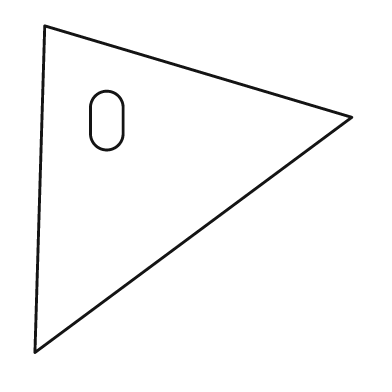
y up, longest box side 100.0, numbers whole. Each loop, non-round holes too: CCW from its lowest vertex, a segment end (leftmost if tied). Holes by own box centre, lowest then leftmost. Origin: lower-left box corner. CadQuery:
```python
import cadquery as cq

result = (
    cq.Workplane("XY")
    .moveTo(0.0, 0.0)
    .lineTo(97.0, 72.0)
    .lineTo(3.0, 100.0)
    .close()
    .moveTo(17.0, 67.0)
    .threePointArc((22.0, 62.0), (27.0, 67.0))
    .lineTo(27.0, 75.0)
    .threePointArc((22.0, 80.0), (17.0, 75.0))
    .close()
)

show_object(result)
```